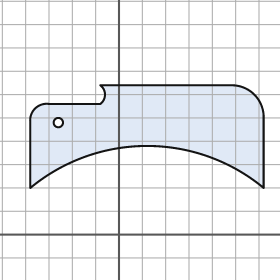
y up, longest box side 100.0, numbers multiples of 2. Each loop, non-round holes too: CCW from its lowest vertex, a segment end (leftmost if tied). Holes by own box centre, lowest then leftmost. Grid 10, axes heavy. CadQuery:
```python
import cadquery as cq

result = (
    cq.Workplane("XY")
    .moveTo(-38.0, 20.0)
    .threePointArc((12.0, 38.0), (62.0, 20.0))
    .lineTo(62.0, 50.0)
    .threePointArc((58.0, 60.0), (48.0, 64.0))
    .lineTo(-8.0, 64.0)
    .threePointArc((-6.0, 60.0), (-8.0, 56.0))
    .lineTo(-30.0, 56.0)
    .threePointArc((-36.0, 54.0), (-38.0, 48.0))
    .close()
    .moveTo(-26.0, 48.0)
    .circle(2.0)
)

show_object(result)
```